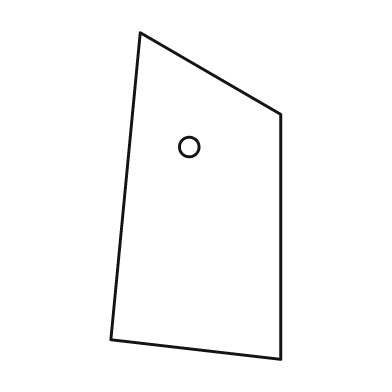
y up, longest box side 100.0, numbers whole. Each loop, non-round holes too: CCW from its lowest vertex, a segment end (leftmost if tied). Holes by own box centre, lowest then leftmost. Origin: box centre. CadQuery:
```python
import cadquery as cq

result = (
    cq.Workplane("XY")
    .moveTo(26.0, -50.0)
    .lineTo(26.0, 25.0)
    .lineTo(-17.0, 50.0)
    .lineTo(-26.0, -44.0)
    .close()
    .moveTo(-2.0, 15.0)
    .circle(3.0)
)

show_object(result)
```